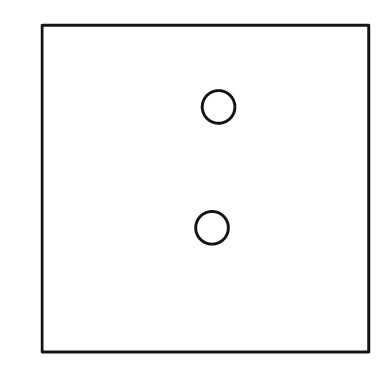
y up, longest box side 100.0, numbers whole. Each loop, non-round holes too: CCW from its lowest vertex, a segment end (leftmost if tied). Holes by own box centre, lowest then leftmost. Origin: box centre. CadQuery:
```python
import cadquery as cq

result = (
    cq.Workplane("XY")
    .moveTo(-50.0, -50.0)
    .lineTo(50.0, -50.0)
    .lineTo(50.0, 50.0)
    .lineTo(-50.0, 50.0)
    .close()
    .moveTo(2.0, -12.0)
    .circle(5.0)
    .moveTo(4.0, 25.0)
    .circle(5.0)
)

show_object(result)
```